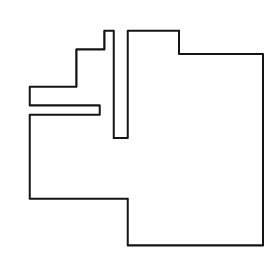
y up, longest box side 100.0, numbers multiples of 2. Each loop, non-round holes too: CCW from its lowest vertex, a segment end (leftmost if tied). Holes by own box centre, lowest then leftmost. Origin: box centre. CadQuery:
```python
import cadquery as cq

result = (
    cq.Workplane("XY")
    .moveTo(-8.0, -46.0)
    .lineTo(50.0, -46.0)
    .lineTo(50.0, 36.0)
    .lineTo(14.0, 36.0)
    .lineTo(14.0, 46.0)
    .lineTo(-8.0, 46.0)
    .lineTo(-8.0, 0.0)
    .lineTo(-14.0, 0.0)
    .lineTo(-14.0, 46.0)
    .lineTo(-18.0, 46.0)
    .lineTo(-18.0, 38.0)
    .lineTo(-30.0, 38.0)
    .lineTo(-30.0, 22.0)
    .lineTo(-50.0, 22.0)
    .lineTo(-50.0, 14.0)
    .lineTo(-20.0, 14.0)
    .lineTo(-20.0, 10.0)
    .lineTo(-50.0, 10.0)
    .lineTo(-50.0, -26.0)
    .lineTo(-8.0, -26.0)
    .close()
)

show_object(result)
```